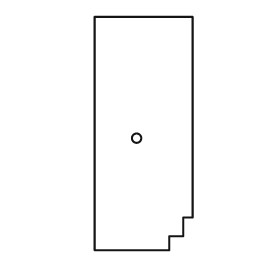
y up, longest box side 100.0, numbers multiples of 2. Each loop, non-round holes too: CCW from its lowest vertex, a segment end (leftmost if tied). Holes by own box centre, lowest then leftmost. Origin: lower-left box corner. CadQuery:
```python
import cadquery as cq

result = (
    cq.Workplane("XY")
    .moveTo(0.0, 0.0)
    .lineTo(32.0, 0.0)
    .lineTo(32.0, 6.0)
    .lineTo(38.0, 6.0)
    .lineTo(38.0, 14.0)
    .lineTo(42.0, 14.0)
    .lineTo(42.0, 100.0)
    .lineTo(0.0, 100.0)
    .close()
    .moveTo(18.0, 48.0)
    .circle(2.0)
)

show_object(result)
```